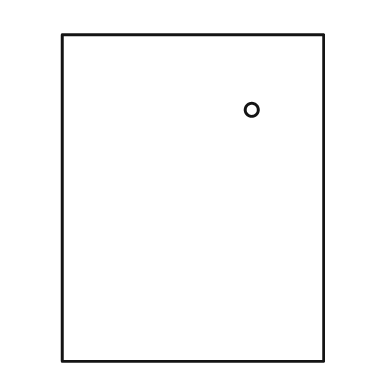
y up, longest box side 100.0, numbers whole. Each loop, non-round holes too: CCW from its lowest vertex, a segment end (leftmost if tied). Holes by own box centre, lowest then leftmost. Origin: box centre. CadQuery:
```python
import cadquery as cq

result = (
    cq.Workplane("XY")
    .moveTo(-40.0, -50.0)
    .lineTo(40.0, -50.0)
    .lineTo(40.0, 50.0)
    .lineTo(-40.0, 50.0)
    .close()
    .moveTo(18.0, 27.0)
    .circle(2.0)
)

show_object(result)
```